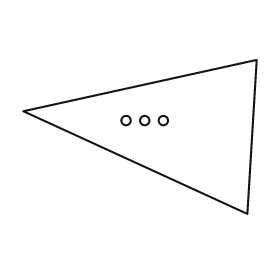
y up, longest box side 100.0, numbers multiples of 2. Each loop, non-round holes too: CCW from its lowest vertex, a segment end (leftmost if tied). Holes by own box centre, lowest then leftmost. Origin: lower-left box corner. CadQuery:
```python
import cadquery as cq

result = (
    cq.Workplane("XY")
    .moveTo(96.0, 0.0)
    .lineTo(100.0, 66.0)
    .lineTo(0.0, 44.0)
    .close()
    .moveTo(44.0, 40.0)
    .circle(2.0)
    .moveTo(52.0, 40.0)
    .circle(2.0)
    .moveTo(60.0, 40.0)
    .circle(2.0)
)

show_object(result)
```